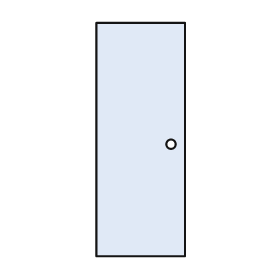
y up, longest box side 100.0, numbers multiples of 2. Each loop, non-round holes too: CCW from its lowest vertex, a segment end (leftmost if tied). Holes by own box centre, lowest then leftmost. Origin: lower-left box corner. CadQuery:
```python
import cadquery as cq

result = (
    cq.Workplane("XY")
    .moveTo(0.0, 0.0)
    .lineTo(38.0, 0.0)
    .lineTo(38.0, 100.0)
    .lineTo(0.0, 100.0)
    .close()
    .moveTo(32.0, 48.0)
    .circle(2.0)
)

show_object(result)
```